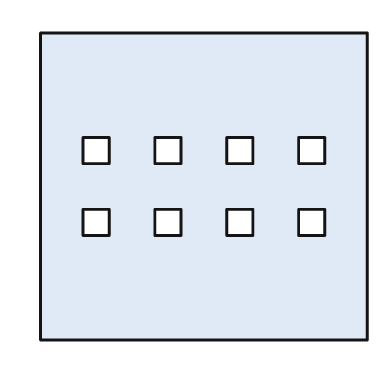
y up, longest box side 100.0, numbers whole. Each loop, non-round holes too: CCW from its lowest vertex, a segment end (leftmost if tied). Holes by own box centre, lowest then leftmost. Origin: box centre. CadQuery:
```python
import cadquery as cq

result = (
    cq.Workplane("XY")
    .moveTo(-50.0, -47.0)
    .lineTo(50.0, -47.0)
    .lineTo(50.0, 47.0)
    .lineTo(-50.0, 47.0)
    .close()
    .moveTo(-37.0, -15.0)
    .lineTo(-29.0, -15.0)
    .lineTo(-29.0, -7.0)
    .lineTo(-37.0, -7.0)
    .close()
    .moveTo(-15.0, -15.0)
    .lineTo(-7.0, -15.0)
    .lineTo(-7.0, -7.0)
    .lineTo(-15.0, -7.0)
    .close()
    .moveTo(7.0, -15.0)
    .lineTo(15.0, -15.0)
    .lineTo(15.0, -7.0)
    .lineTo(7.0, -7.0)
    .close()
    .moveTo(29.0, -15.0)
    .lineTo(37.0, -15.0)
    .lineTo(37.0, -7.0)
    .lineTo(29.0, -7.0)
    .close()
    .moveTo(-37.0, 7.0)
    .lineTo(-29.0, 7.0)
    .lineTo(-29.0, 15.0)
    .lineTo(-37.0, 15.0)
    .close()
    .moveTo(-15.0, 7.0)
    .lineTo(-7.0, 7.0)
    .lineTo(-7.0, 15.0)
    .lineTo(-15.0, 15.0)
    .close()
    .moveTo(7.0, 7.0)
    .lineTo(15.0, 7.0)
    .lineTo(15.0, 15.0)
    .lineTo(7.0, 15.0)
    .close()
    .moveTo(29.0, 7.0)
    .lineTo(37.0, 7.0)
    .lineTo(37.0, 15.0)
    .lineTo(29.0, 15.0)
    .close()
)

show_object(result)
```